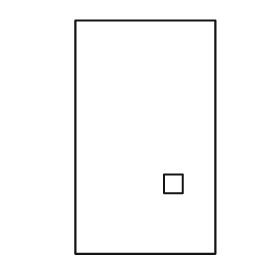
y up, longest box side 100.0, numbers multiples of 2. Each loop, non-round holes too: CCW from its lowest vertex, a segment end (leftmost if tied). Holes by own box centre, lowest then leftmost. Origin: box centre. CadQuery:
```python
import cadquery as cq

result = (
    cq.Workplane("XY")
    .moveTo(-30.0, -50.0)
    .lineTo(30.0, -50.0)
    .lineTo(30.0, 50.0)
    .lineTo(-30.0, 50.0)
    .close()
    .moveTo(8.0, -24.0)
    .lineTo(16.0, -24.0)
    .lineTo(16.0, -16.0)
    .lineTo(8.0, -16.0)
    .close()
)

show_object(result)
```